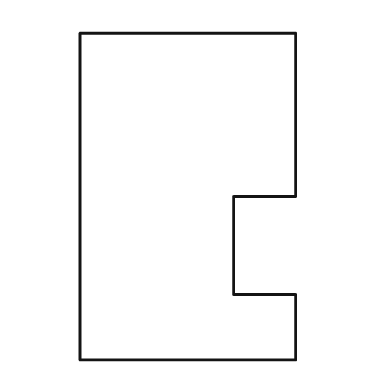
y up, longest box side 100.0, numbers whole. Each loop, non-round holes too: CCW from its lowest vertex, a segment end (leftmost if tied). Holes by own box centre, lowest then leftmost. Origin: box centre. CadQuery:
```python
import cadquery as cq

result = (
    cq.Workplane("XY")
    .moveTo(-33.0, -50.0)
    .lineTo(33.0, -50.0)
    .lineTo(33.0, -30.0)
    .lineTo(14.0, -30.0)
    .lineTo(14.0, 0.0)
    .lineTo(33.0, 0.0)
    .lineTo(33.0, 50.0)
    .lineTo(-33.0, 50.0)
    .close()
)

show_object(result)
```